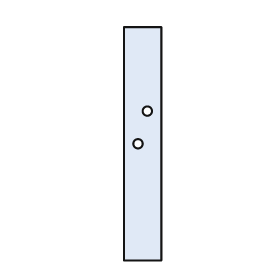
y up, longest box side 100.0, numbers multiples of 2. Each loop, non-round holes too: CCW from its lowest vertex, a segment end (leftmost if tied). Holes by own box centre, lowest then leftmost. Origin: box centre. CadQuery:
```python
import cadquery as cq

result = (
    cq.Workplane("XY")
    .moveTo(-8.0, -50.0)
    .lineTo(8.0, -50.0)
    .lineTo(8.0, 50.0)
    .lineTo(-8.0, 50.0)
    .close()
    .moveTo(-2.0, 0.0)
    .circle(2.0)
    .moveTo(2.0, 14.0)
    .circle(2.0)
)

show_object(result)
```